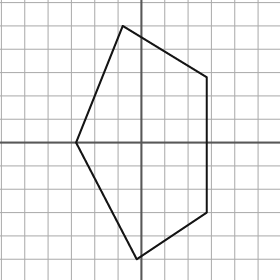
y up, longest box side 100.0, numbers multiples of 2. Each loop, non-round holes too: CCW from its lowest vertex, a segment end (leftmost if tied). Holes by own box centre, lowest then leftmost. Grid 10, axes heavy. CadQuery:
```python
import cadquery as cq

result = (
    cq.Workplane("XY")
    .moveTo(-2.0, -50.0)
    .lineTo(28.0, -30.0)
    .lineTo(28.0, 28.0)
    .lineTo(-8.0, 50.0)
    .lineTo(-28.0, 0.0)
    .close()
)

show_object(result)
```